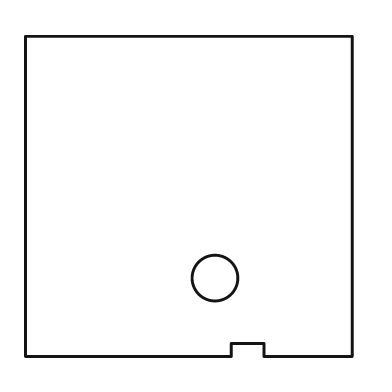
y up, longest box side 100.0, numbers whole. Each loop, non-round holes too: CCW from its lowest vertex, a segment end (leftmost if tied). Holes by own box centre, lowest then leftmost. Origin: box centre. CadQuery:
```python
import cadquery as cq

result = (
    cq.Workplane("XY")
    .moveTo(-50.0, -49.0)
    .lineTo(13.0, -49.0)
    .lineTo(13.0, -45.0)
    .lineTo(23.0, -45.0)
    .lineTo(23.0, -49.0)
    .lineTo(50.0, -49.0)
    .lineTo(50.0, 49.0)
    .lineTo(-50.0, 49.0)
    .close()
    .moveTo(8.0, -25.0)
    .circle(7.0)
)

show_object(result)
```